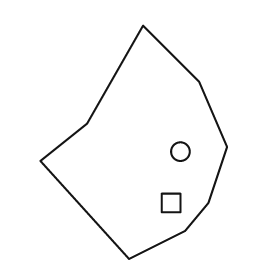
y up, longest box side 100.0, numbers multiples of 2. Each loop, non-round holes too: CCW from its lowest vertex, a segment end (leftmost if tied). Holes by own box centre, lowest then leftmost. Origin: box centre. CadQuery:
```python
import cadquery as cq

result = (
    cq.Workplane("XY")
    .moveTo(-2.0, -50.0)
    .lineTo(22.0, -38.0)
    .lineTo(32.0, -26.0)
    .lineTo(40.0, -2.0)
    .lineTo(28.0, 26.0)
    .lineTo(4.0, 50.0)
    .lineTo(-20.0, 8.0)
    .lineTo(-40.0, -8.0)
    .close()
    .moveTo(12.0, -30.0)
    .lineTo(20.0, -30.0)
    .lineTo(20.0, -22.0)
    .lineTo(12.0, -22.0)
    .close()
    .moveTo(20.0, -4.0)
    .circle(4.0)
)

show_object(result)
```